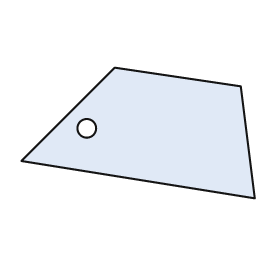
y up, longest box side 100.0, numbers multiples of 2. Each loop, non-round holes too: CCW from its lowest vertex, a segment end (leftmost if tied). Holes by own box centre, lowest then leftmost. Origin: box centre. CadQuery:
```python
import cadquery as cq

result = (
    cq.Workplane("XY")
    .moveTo(50.0, -28.0)
    .lineTo(44.0, 20.0)
    .lineTo(-10.0, 28.0)
    .lineTo(-50.0, -12.0)
    .close()
    .moveTo(-22.0, 2.0)
    .circle(4.0)
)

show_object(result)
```